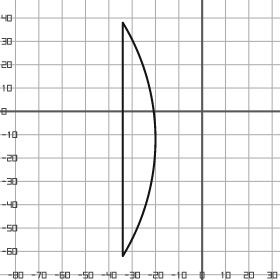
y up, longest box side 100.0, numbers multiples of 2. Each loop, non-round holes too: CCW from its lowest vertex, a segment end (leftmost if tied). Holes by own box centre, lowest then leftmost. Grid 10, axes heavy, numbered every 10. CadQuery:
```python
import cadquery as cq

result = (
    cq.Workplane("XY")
    .moveTo(-34.0, -62.0)
    .threePointArc((-20.0, -12.0), (-34.0, 38.0))
    .close()
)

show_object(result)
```